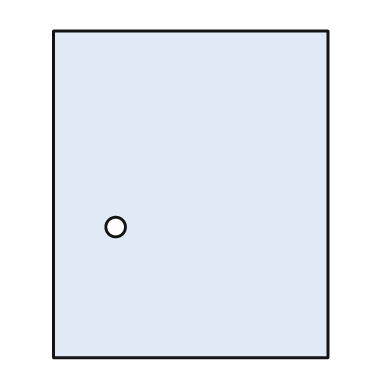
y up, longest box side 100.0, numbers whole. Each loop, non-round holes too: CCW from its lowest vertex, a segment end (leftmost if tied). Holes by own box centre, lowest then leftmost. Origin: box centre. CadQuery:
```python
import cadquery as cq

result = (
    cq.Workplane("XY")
    .moveTo(-42.0, -50.0)
    .lineTo(42.0, -50.0)
    .lineTo(42.0, 50.0)
    .lineTo(-42.0, 50.0)
    .close()
    .moveTo(-23.0, -10.0)
    .circle(3.0)
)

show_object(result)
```